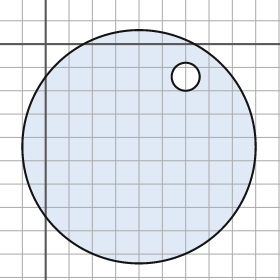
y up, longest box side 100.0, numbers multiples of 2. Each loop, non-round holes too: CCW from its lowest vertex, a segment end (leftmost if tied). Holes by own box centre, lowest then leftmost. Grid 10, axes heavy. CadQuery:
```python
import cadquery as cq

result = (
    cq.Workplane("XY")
    .moveTo(40.0, -44.0)
    .circle(50.0)
    .moveTo(60.0, -14.0)
    .circle(6.0)
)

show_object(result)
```